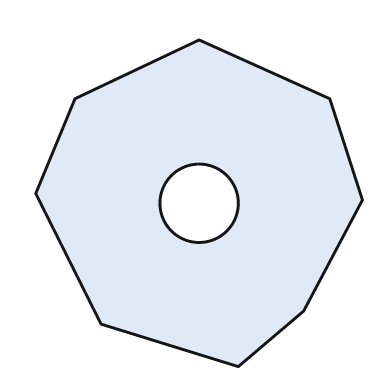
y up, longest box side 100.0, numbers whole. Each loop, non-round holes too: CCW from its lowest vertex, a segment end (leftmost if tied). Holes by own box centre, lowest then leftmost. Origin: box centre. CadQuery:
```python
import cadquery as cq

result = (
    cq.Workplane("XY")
    .moveTo(12.0, -50.0)
    .lineTo(32.0, -33.0)
    .lineTo(50.0, 1.0)
    .lineTo(40.0, 32.0)
    .lineTo(0.0, 50.0)
    .lineTo(-38.0, 32.0)
    .lineTo(-50.0, 3.0)
    .lineTo(-30.0, -37.0)
    .close()
    .moveTo(0.0, 0.0)
    .circle(12.0)
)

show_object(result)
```